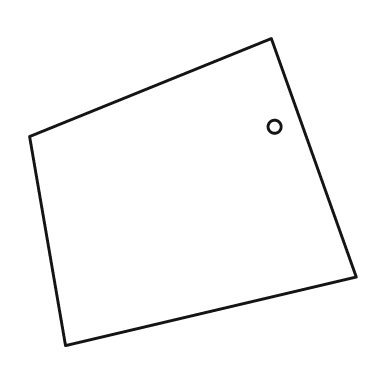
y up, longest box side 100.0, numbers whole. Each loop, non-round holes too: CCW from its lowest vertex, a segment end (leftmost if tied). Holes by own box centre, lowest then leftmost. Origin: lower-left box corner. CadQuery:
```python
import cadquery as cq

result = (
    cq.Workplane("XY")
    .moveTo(11.0, 0.0)
    .lineTo(100.0, 21.0)
    .lineTo(74.0, 94.0)
    .lineTo(0.0, 64.0)
    .close()
    .moveTo(75.0, 67.0)
    .circle(2.0)
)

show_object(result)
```